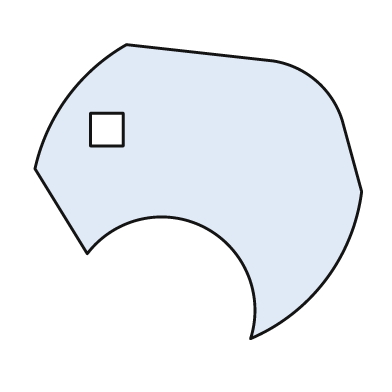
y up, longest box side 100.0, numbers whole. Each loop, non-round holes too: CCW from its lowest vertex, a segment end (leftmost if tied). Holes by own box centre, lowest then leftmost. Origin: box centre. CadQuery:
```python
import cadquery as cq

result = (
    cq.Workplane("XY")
    .moveTo(16.0, -45.0)
    .threePointArc((39.0, -27.0), (50.0, 0.0))
    .lineTo(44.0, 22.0)
    .threePointArc((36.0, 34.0), (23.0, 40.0))
    .lineTo(-22.0, 45.0)
    .threePointArc((-40.0, 29.0), (-50.0, 7.0))
    .lineTo(-34.0, -19.0)
    .threePointArc((2.0, -11.0), (16.0, -45.0))
    .close()
    .moveTo(-33.0, 14.0)
    .lineTo(-23.0, 14.0)
    .lineTo(-23.0, 24.0)
    .lineTo(-33.0, 24.0)
    .close()
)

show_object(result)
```